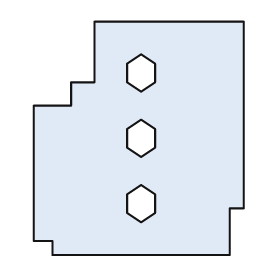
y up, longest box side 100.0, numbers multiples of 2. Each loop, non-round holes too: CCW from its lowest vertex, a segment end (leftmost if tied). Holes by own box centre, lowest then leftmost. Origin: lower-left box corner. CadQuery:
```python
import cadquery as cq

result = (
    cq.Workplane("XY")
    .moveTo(8.0, 0.0)
    .lineTo(84.0, 0.0)
    .lineTo(84.0, 20.0)
    .lineTo(90.0, 20.0)
    .lineTo(90.0, 100.0)
    .lineTo(26.0, 100.0)
    .lineTo(26.0, 74.0)
    .lineTo(16.0, 74.0)
    .lineTo(16.0, 64.0)
    .lineTo(0.0, 64.0)
    .lineTo(0.0, 6.0)
    .lineTo(8.0, 6.0)
    .close()
    .moveTo(46.0, 14.0)
    .lineTo(52.0, 18.0)
    .lineTo(52.0, 26.0)
    .lineTo(46.0, 30.0)
    .lineTo(40.0, 26.0)
    .lineTo(40.0, 18.0)
    .close()
    .moveTo(46.0, 42.0)
    .lineTo(52.0, 46.0)
    .lineTo(52.0, 54.0)
    .lineTo(46.0, 58.0)
    .lineTo(40.0, 54.0)
    .lineTo(40.0, 46.0)
    .close()
    .moveTo(46.0, 70.0)
    .lineTo(52.0, 74.0)
    .lineTo(52.0, 82.0)
    .lineTo(46.0, 86.0)
    .lineTo(40.0, 82.0)
    .lineTo(40.0, 74.0)
    .close()
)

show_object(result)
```